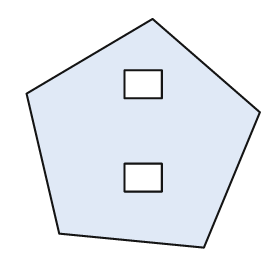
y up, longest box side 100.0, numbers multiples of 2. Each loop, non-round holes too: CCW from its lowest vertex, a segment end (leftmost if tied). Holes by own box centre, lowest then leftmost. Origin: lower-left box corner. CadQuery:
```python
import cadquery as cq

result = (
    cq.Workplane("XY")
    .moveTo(76.0, 0.0)
    .lineTo(100.0, 58.0)
    .lineTo(54.0, 98.0)
    .lineTo(0.0, 66.0)
    .lineTo(14.0, 6.0)
    .close()
    .moveTo(42.0, 24.0)
    .lineTo(58.0, 24.0)
    .lineTo(58.0, 36.0)
    .lineTo(42.0, 36.0)
    .close()
    .moveTo(42.0, 64.0)
    .lineTo(58.0, 64.0)
    .lineTo(58.0, 76.0)
    .lineTo(42.0, 76.0)
    .close()
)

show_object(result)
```